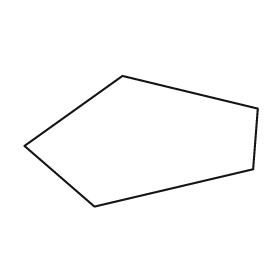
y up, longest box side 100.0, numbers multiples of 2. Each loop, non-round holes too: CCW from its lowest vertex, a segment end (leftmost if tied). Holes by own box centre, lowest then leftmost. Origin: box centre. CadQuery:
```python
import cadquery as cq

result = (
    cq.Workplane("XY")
    .moveTo(-20.0, -28.0)
    .lineTo(48.0, -12.0)
    .lineTo(50.0, 14.0)
    .lineTo(-8.0, 28.0)
    .lineTo(-50.0, -2.0)
    .close()
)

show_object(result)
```